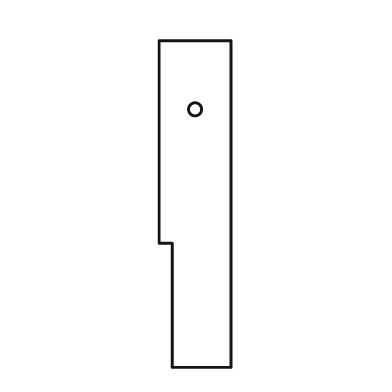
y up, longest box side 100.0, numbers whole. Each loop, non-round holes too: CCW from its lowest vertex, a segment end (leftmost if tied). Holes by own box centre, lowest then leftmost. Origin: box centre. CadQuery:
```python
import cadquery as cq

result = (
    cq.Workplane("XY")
    .moveTo(-7.0, -50.0)
    .lineTo(11.0, -50.0)
    .lineTo(11.0, 50.0)
    .lineTo(-11.0, 50.0)
    .lineTo(-11.0, -12.0)
    .lineTo(-7.0, -12.0)
    .close()
    .moveTo(0.0, 29.0)
    .circle(2.0)
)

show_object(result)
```